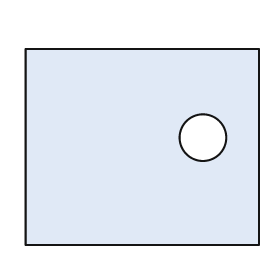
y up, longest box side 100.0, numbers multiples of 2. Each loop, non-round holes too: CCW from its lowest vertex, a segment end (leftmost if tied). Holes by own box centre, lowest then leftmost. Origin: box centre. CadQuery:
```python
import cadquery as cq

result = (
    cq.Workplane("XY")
    .moveTo(-50.0, -42.0)
    .lineTo(50.0, -42.0)
    .lineTo(50.0, 42.0)
    .lineTo(-50.0, 42.0)
    .close()
    .moveTo(26.0, 4.0)
    .circle(10.0)
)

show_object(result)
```